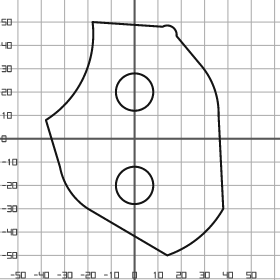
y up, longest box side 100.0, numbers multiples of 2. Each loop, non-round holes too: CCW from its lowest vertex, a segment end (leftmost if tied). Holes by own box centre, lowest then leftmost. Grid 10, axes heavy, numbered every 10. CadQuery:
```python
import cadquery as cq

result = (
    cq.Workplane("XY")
    .moveTo(14.0, -50.0)
    .threePointArc((28.0, -42.0), (38.0, -30.0))
    .lineTo(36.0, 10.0)
    .threePointArc((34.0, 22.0), (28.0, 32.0))
    .lineTo(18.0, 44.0)
    .threePointArc((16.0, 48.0), (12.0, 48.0))
    .lineTo(-18.0, 50.0)
    .threePointArc((-22.0, 26.0), (-38.0, 8.0))
    .lineTo(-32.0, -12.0)
    .threePointArc((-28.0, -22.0), (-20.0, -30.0))
    .close()
    .moveTo(0.0, -20.0)
    .circle(8.0)
    .moveTo(0.0, 20.0)
    .circle(8.0)
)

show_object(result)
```